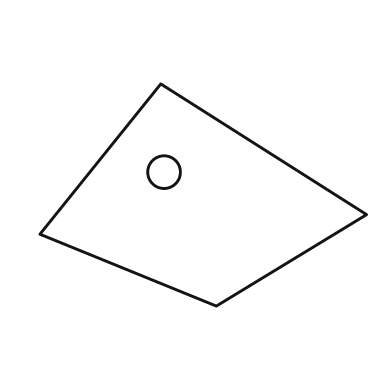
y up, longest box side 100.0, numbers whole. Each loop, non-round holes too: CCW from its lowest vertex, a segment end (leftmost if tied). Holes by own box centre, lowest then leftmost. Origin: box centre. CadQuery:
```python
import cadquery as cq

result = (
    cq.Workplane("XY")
    .moveTo(4.0, -34.0)
    .lineTo(50.0, -6.0)
    .lineTo(-13.0, 34.0)
    .lineTo(-50.0, -12.0)
    .close()
    .moveTo(-12.0, 7.0)
    .circle(5.0)
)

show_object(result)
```